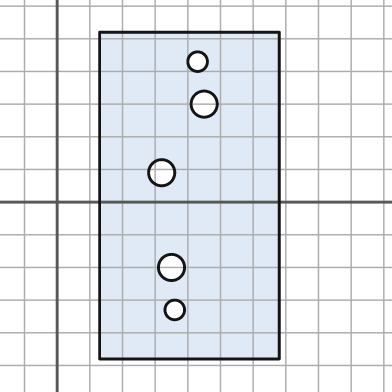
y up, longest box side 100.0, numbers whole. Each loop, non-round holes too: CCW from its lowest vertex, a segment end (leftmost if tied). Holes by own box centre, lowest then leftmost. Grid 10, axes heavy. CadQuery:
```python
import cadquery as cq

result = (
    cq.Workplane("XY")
    .moveTo(13.0, -48.0)
    .lineTo(68.0, -48.0)
    .lineTo(68.0, 52.0)
    .lineTo(13.0, 52.0)
    .close()
    .moveTo(36.0, -33.0)
    .circle(3.0)
    .moveTo(35.0, -20.0)
    .circle(4.0)
    .moveTo(32.0, 9.0)
    .circle(4.0)
    .moveTo(45.0, 30.0)
    .circle(4.0)
    .moveTo(43.0, 43.0)
    .circle(3.0)
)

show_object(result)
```